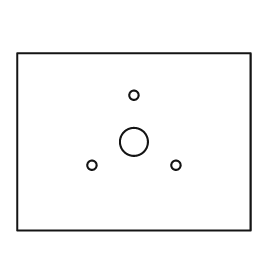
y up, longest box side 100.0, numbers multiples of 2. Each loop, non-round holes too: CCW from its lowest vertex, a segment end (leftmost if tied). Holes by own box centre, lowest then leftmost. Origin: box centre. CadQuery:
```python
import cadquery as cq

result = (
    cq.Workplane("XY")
    .moveTo(-50.0, -38.0)
    .lineTo(50.0, -38.0)
    .lineTo(50.0, 38.0)
    .lineTo(-50.0, 38.0)
    .close()
    .moveTo(-18.0, -10.0)
    .circle(2.0)
    .moveTo(18.0, -10.0)
    .circle(2.0)
    .moveTo(0.0, 0.0)
    .circle(6.0)
    .moveTo(0.0, 20.0)
    .circle(2.0)
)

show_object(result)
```